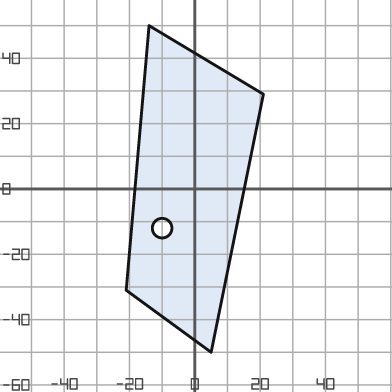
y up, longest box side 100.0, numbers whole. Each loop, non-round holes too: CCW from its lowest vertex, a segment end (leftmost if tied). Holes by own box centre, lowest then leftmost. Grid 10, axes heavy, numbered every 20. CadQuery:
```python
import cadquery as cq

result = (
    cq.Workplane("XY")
    .moveTo(5.0, -50.0)
    .lineTo(21.0, 29.0)
    .lineTo(-14.0, 50.0)
    .lineTo(-21.0, -31.0)
    .close()
    .moveTo(-10.0, -12.0)
    .circle(3.0)
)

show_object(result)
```